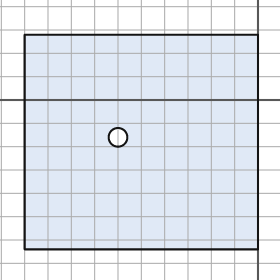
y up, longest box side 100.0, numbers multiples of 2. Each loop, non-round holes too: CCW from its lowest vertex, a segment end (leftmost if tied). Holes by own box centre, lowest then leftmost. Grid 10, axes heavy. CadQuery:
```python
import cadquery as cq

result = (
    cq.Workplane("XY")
    .moveTo(-100.0, -64.0)
    .lineTo(0.0, -64.0)
    .lineTo(0.0, 28.0)
    .lineTo(-100.0, 28.0)
    .close()
    .moveTo(-60.0, -16.0)
    .circle(4.0)
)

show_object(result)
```